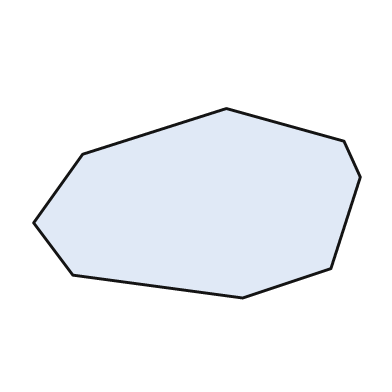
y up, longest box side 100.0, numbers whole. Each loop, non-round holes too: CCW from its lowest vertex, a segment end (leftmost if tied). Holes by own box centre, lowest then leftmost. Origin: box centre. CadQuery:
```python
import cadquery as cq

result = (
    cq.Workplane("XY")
    .moveTo(14.0, -29.0)
    .lineTo(41.0, -20.0)
    .lineTo(50.0, 8.0)
    .lineTo(45.0, 19.0)
    .lineTo(9.0, 29.0)
    .lineTo(-35.0, 15.0)
    .lineTo(-50.0, -6.0)
    .lineTo(-38.0, -22.0)
    .close()
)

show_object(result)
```